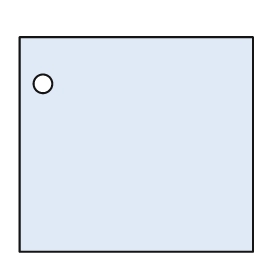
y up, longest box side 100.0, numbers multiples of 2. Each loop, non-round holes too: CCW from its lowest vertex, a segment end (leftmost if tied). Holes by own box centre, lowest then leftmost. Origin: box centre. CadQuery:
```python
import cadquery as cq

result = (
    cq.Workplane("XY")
    .moveTo(-50.0, -46.0)
    .lineTo(50.0, -46.0)
    .lineTo(50.0, 46.0)
    .lineTo(-50.0, 46.0)
    .close()
    .moveTo(-40.0, 26.0)
    .circle(4.0)
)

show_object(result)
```